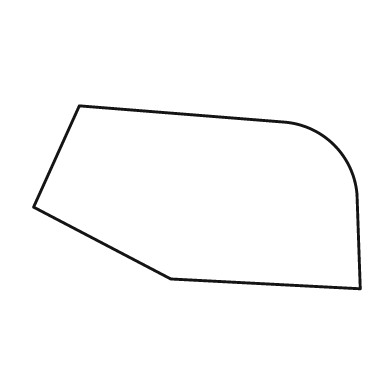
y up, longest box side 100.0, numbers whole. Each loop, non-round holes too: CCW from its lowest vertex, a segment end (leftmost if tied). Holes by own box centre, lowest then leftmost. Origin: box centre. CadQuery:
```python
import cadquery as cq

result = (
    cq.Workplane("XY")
    .moveTo(50.0, -28.0)
    .lineTo(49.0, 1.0)
    .threePointArc((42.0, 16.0), (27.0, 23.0))
    .lineTo(-36.0, 28.0)
    .lineTo(-50.0, -3.0)
    .lineTo(-8.0, -25.0)
    .close()
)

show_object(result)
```